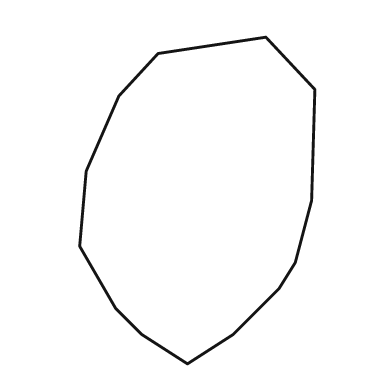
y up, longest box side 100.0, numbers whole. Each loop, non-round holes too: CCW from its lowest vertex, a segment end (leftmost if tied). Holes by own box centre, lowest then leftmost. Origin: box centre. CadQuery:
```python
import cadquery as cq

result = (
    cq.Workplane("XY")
    .moveTo(-3.0, -50.0)
    .lineTo(11.0, -41.0)
    .lineTo(25.0, -27.0)
    .lineTo(30.0, -19.0)
    .lineTo(35.0, 0.0)
    .lineTo(36.0, 34.0)
    .lineTo(21.0, 50.0)
    .lineTo(-12.0, 45.0)
    .lineTo(-24.0, 32.0)
    .lineTo(-34.0, 9.0)
    .lineTo(-36.0, -14.0)
    .lineTo(-25.0, -33.0)
    .lineTo(-17.0, -41.0)
    .close()
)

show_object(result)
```